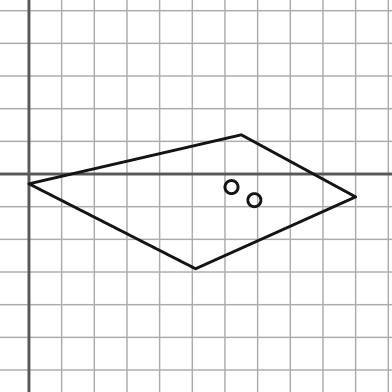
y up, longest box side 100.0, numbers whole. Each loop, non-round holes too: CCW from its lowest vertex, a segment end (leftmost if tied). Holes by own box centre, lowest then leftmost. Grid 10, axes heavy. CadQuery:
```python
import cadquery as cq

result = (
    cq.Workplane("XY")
    .moveTo(51.0, -29.0)
    .lineTo(100.0, -7.0)
    .lineTo(65.0, 12.0)
    .lineTo(0.0, -3.0)
    .close()
    .moveTo(69.0, -8.0)
    .circle(2.0)
    .moveTo(62.0, -4.0)
    .circle(2.0)
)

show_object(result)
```